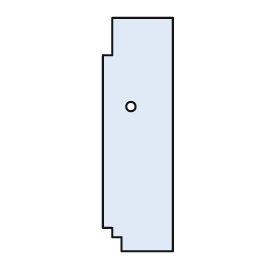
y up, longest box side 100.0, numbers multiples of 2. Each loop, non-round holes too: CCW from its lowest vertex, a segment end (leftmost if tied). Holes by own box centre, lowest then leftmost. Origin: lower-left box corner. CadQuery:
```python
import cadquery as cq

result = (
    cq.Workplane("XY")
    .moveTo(8.0, 0.0)
    .lineTo(30.0, 0.0)
    .lineTo(30.0, 100.0)
    .lineTo(4.0, 100.0)
    .lineTo(4.0, 84.0)
    .lineTo(0.0, 84.0)
    .lineTo(0.0, 10.0)
    .lineTo(4.0, 10.0)
    .lineTo(4.0, 6.0)
    .lineTo(8.0, 6.0)
    .close()
    .moveTo(12.0, 62.0)
    .circle(2.0)
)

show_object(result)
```